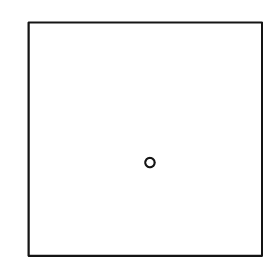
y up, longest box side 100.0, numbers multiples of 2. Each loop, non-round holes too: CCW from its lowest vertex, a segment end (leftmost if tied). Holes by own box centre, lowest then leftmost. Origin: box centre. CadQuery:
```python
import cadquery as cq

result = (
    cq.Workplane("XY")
    .moveTo(-50.0, -50.0)
    .lineTo(50.0, -50.0)
    .lineTo(50.0, 50.0)
    .lineTo(-50.0, 50.0)
    .close()
    .moveTo(2.0, -10.0)
    .circle(2.0)
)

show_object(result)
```